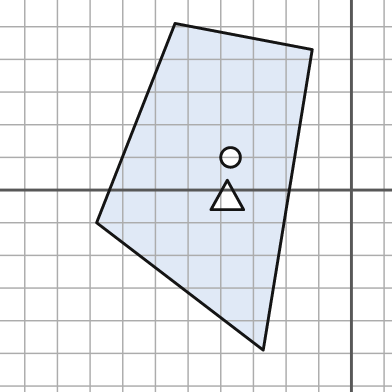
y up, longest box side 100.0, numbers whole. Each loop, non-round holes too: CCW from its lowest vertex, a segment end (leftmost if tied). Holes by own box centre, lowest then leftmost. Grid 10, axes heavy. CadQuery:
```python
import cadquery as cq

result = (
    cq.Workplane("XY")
    .moveTo(-27.0, -49.0)
    .lineTo(-12.0, 43.0)
    .lineTo(-54.0, 51.0)
    .lineTo(-78.0, -10.0)
    .close()
    .moveTo(-43.0, -6.0)
    .lineTo(-33.0, -6.0)
    .lineTo(-38.0, 3.0)
    .close()
    .moveTo(-37.0, 10.0)
    .circle(3.0)
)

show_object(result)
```